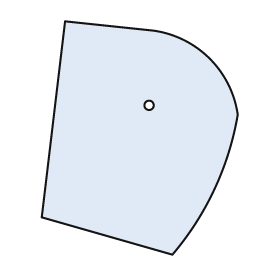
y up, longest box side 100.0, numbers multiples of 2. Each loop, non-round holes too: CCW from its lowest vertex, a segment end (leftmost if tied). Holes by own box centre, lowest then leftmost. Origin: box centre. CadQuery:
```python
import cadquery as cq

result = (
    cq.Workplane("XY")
    .moveTo(14.0, -50.0)
    .threePointArc((32.0, -22.0), (42.0, 10.0))
    .threePointArc((30.0, 34.0), (6.0, 46.0))
    .lineTo(-32.0, 50.0)
    .lineTo(-42.0, -34.0)
    .close()
    .moveTo(4.0, 14.0)
    .circle(2.0)
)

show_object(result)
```